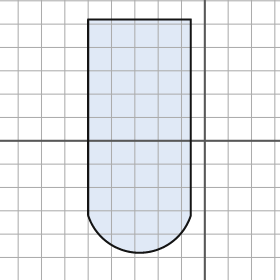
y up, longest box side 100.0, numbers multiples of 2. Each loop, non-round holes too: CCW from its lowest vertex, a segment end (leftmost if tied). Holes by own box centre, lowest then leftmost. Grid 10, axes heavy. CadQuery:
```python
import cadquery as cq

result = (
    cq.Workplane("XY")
    .moveTo(-50.0, -32.0)
    .threePointArc((-28.0, -48.0), (-6.0, -32.0))
    .lineTo(-6.0, 52.0)
    .lineTo(-50.0, 52.0)
    .close()
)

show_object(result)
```